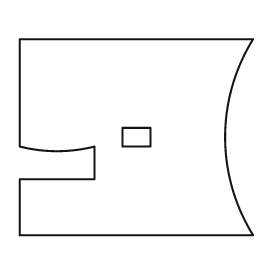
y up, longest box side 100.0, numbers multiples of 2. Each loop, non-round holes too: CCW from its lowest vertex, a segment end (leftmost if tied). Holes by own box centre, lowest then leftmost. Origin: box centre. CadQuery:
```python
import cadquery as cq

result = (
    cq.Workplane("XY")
    .moveTo(-50.0, -42.0)
    .lineTo(50.0, -42.0)
    .threePointArc((38.0, 0.0), (50.0, 42.0))
    .lineTo(-50.0, 42.0)
    .lineTo(-50.0, -4.0)
    .threePointArc((-34.0, -6.0), (-18.0, -4.0))
    .lineTo(-18.0, -18.0)
    .lineTo(-50.0, -18.0)
    .close()
    .moveTo(-6.0, -4.0)
    .lineTo(6.0, -4.0)
    .lineTo(6.0, 4.0)
    .lineTo(-6.0, 4.0)
    .close()
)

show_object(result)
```